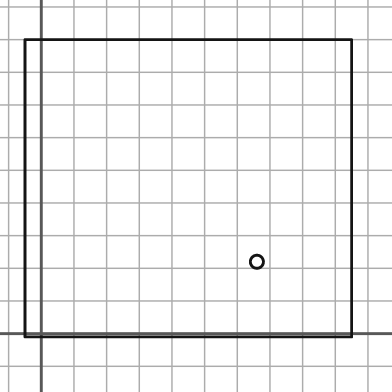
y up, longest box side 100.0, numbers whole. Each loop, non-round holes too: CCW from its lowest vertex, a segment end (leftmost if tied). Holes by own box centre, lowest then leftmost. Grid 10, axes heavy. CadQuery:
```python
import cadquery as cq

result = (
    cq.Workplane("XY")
    .moveTo(-5.0, -1.0)
    .lineTo(95.0, -1.0)
    .lineTo(95.0, 90.0)
    .lineTo(-5.0, 90.0)
    .close()
    .moveTo(66.0, 22.0)
    .circle(2.0)
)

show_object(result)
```